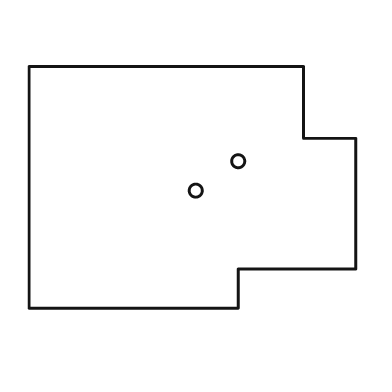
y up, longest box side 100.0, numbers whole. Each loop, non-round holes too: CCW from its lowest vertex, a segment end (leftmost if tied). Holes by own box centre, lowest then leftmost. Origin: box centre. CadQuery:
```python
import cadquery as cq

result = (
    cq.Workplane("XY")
    .moveTo(-50.0, -37.0)
    .lineTo(14.0, -37.0)
    .lineTo(14.0, -25.0)
    .lineTo(50.0, -25.0)
    .lineTo(50.0, 15.0)
    .lineTo(34.0, 15.0)
    .lineTo(34.0, 37.0)
    .lineTo(-50.0, 37.0)
    .close()
    .moveTo(1.0, -1.0)
    .circle(2.0)
    .moveTo(14.0, 8.0)
    .circle(2.0)
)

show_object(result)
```